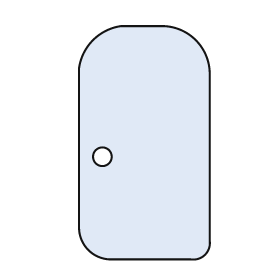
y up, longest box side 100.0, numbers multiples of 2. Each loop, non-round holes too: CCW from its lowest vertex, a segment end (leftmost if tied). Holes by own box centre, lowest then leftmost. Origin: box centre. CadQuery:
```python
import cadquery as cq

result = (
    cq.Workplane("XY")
    .moveTo(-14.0, -50.0)
    .lineTo(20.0, -50.0)
    .threePointArc((26.0, -48.0), (28.0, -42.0))
    .lineTo(28.0, 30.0)
    .threePointArc((22.0, 44.0), (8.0, 50.0))
    .lineTo(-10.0, 50.0)
    .threePointArc((-22.0, 44.0), (-28.0, 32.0))
    .lineTo(-28.0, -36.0)
    .threePointArc((-24.0, -46.0), (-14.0, -50.0))
    .close()
    .moveTo(-18.0, -6.0)
    .circle(4.0)
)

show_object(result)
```